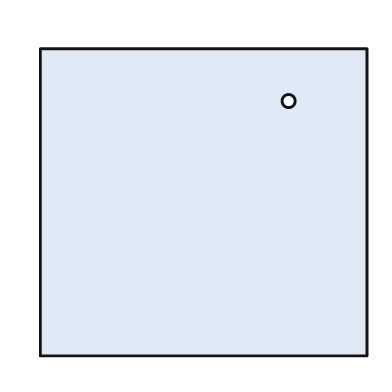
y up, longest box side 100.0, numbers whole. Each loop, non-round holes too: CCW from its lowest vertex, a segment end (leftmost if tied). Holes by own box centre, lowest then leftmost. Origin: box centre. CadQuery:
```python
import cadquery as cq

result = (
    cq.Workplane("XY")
    .moveTo(-50.0, -47.0)
    .lineTo(50.0, -47.0)
    .lineTo(50.0, 47.0)
    .lineTo(-50.0, 47.0)
    .close()
    .moveTo(26.0, 31.0)
    .circle(2.0)
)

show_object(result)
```